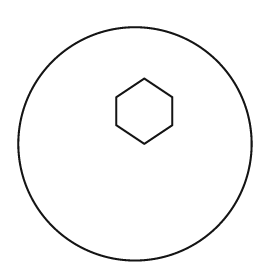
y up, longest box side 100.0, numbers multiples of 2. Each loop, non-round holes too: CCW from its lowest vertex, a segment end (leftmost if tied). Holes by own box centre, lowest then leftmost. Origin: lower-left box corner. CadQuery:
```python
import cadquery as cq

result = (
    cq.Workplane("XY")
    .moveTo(50.0, 50.0)
    .circle(50.0)
    .moveTo(54.0, 50.0)
    .lineTo(66.0, 58.0)
    .lineTo(66.0, 70.0)
    .lineTo(54.0, 78.0)
    .lineTo(42.0, 70.0)
    .lineTo(42.0, 58.0)
    .close()
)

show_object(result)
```